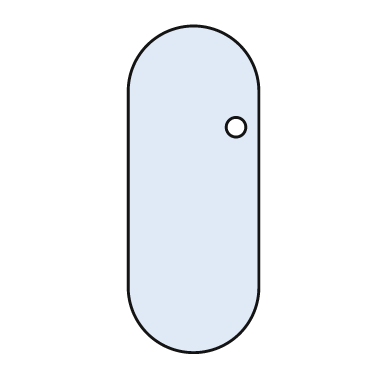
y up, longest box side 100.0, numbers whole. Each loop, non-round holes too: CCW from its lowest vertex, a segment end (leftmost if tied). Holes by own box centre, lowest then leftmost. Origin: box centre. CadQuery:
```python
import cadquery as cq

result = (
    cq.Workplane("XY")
    .moveTo(-20.0, -30.0)
    .threePointArc((0.0, -50.0), (20.0, -30.0))
    .lineTo(20.0, 30.0)
    .threePointArc((0.0, 50.0), (-20.0, 30.0))
    .close()
    .moveTo(13.0, 19.0)
    .circle(3.0)
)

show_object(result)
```